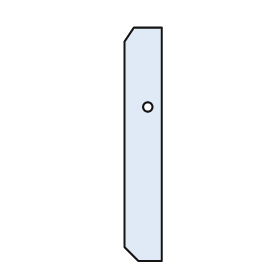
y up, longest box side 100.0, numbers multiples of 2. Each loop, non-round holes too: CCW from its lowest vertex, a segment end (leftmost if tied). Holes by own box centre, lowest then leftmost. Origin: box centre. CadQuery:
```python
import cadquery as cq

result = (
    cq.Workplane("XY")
    .moveTo(-2.0, -50.0)
    .lineTo(8.0, -50.0)
    .lineTo(8.0, 50.0)
    .lineTo(-4.0, 50.0)
    .lineTo(-8.0, 44.0)
    .lineTo(-8.0, -44.0)
    .close()
    .moveTo(2.0, 16.0)
    .circle(2.0)
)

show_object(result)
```